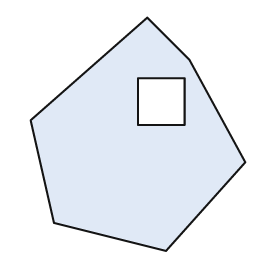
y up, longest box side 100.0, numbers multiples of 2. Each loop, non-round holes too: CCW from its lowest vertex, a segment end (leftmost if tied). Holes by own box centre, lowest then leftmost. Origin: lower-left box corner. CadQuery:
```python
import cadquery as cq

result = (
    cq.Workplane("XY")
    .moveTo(58.0, 0.0)
    .lineTo(92.0, 38.0)
    .lineTo(68.0, 82.0)
    .lineTo(50.0, 100.0)
    .lineTo(0.0, 56.0)
    .lineTo(10.0, 12.0)
    .close()
    .moveTo(46.0, 54.0)
    .lineTo(66.0, 54.0)
    .lineTo(66.0, 74.0)
    .lineTo(46.0, 74.0)
    .close()
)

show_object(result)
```